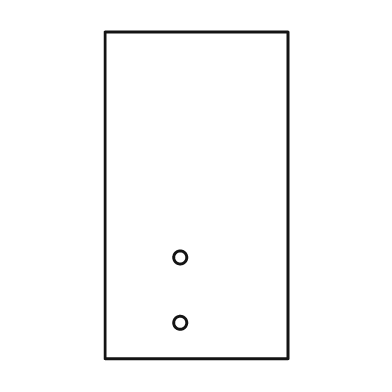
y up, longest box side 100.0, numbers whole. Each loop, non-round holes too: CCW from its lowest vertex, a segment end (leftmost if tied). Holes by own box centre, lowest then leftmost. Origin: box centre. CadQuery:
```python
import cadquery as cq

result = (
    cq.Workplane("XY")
    .moveTo(-28.0, -50.0)
    .lineTo(28.0, -50.0)
    .lineTo(28.0, 50.0)
    .lineTo(-28.0, 50.0)
    .close()
    .moveTo(-5.0, -39.0)
    .circle(2.0)
    .moveTo(-5.0, -19.0)
    .circle(2.0)
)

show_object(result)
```